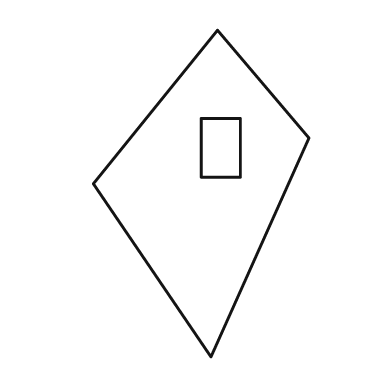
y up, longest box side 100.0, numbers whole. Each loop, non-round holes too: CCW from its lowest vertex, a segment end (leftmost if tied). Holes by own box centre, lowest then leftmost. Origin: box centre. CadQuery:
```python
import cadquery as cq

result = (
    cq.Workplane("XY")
    .moveTo(3.0, -50.0)
    .lineTo(33.0, 17.0)
    .lineTo(5.0, 50.0)
    .lineTo(-33.0, 3.0)
    .close()
    .moveTo(0.0, 5.0)
    .lineTo(12.0, 5.0)
    .lineTo(12.0, 23.0)
    .lineTo(0.0, 23.0)
    .close()
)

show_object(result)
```